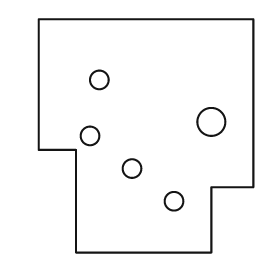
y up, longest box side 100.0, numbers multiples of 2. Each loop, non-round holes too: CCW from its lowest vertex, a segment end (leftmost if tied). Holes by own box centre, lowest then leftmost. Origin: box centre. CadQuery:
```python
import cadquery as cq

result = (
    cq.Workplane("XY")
    .moveTo(-30.0, -50.0)
    .lineTo(28.0, -50.0)
    .lineTo(28.0, -22.0)
    .lineTo(46.0, -22.0)
    .lineTo(46.0, 50.0)
    .lineTo(-46.0, 50.0)
    .lineTo(-46.0, -6.0)
    .lineTo(-30.0, -6.0)
    .close()
    .moveTo(12.0, -28.0)
    .circle(4.0)
    .moveTo(-6.0, -14.0)
    .circle(4.0)
    .moveTo(-24.0, 0.0)
    .circle(4.0)
    .moveTo(28.0, 6.0)
    .circle(6.0)
    .moveTo(-20.0, 24.0)
    .circle(4.0)
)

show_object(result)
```